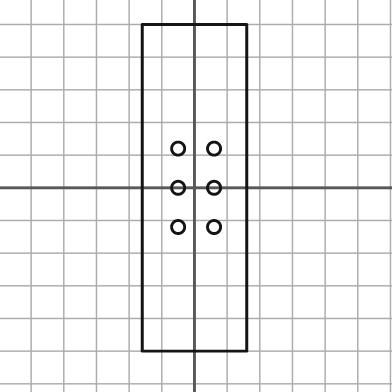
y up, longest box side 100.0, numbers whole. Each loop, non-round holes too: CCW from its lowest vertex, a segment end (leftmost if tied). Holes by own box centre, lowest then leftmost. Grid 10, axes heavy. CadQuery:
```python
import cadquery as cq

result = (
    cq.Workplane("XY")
    .moveTo(-16.0, -50.0)
    .lineTo(16.0, -50.0)
    .lineTo(16.0, 50.0)
    .lineTo(-16.0, 50.0)
    .close()
    .moveTo(-5.0, -12.0)
    .circle(2.0)
    .moveTo(6.0, -12.0)
    .circle(2.0)
    .moveTo(-5.0, 0.0)
    .circle(2.0)
    .moveTo(6.0, 0.0)
    .circle(2.0)
    .moveTo(-5.0, 12.0)
    .circle(2.0)
    .moveTo(6.0, 12.0)
    .circle(2.0)
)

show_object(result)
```